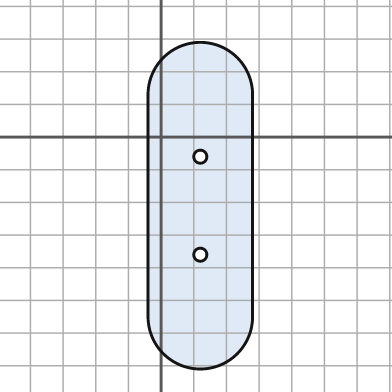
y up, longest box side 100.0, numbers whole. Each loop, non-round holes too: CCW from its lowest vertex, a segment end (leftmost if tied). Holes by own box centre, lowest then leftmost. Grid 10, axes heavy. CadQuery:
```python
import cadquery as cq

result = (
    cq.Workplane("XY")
    .moveTo(-4.0, -55.0)
    .threePointArc((12.0, -71.0), (28.0, -55.0))
    .lineTo(28.0, 13.0)
    .threePointArc((12.0, 29.0), (-4.0, 13.0))
    .close()
    .moveTo(12.0, -36.0)
    .circle(2.0)
    .moveTo(12.0, -6.0)
    .circle(2.0)
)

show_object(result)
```